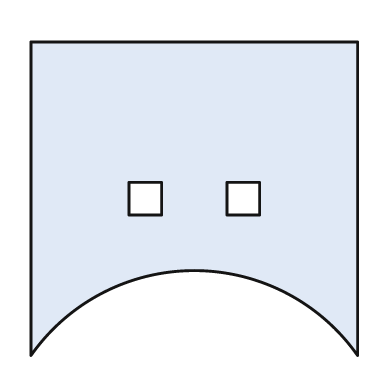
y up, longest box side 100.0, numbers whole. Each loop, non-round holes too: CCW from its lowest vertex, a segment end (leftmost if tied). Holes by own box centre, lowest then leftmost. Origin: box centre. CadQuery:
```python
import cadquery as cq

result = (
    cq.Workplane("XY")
    .moveTo(-50.0, -48.0)
    .threePointArc((0.0, -22.0), (50.0, -48.0))
    .lineTo(50.0, 48.0)
    .lineTo(-50.0, 48.0)
    .close()
    .moveTo(-20.0, -5.0)
    .lineTo(-10.0, -5.0)
    .lineTo(-10.0, 5.0)
    .lineTo(-20.0, 5.0)
    .close()
    .moveTo(10.0, -5.0)
    .lineTo(20.0, -5.0)
    .lineTo(20.0, 5.0)
    .lineTo(10.0, 5.0)
    .close()
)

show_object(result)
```